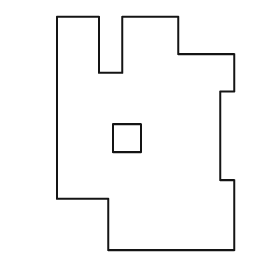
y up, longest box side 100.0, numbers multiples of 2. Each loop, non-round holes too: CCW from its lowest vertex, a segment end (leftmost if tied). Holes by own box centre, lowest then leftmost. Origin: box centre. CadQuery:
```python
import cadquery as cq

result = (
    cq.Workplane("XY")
    .moveTo(-16.0, -50.0)
    .lineTo(38.0, -50.0)
    .lineTo(38.0, -20.0)
    .lineTo(32.0, -20.0)
    .lineTo(32.0, 18.0)
    .lineTo(38.0, 18.0)
    .lineTo(38.0, 34.0)
    .lineTo(14.0, 34.0)
    .lineTo(14.0, 50.0)
    .lineTo(-10.0, 50.0)
    .lineTo(-10.0, 26.0)
    .lineTo(-20.0, 26.0)
    .lineTo(-20.0, 50.0)
    .lineTo(-38.0, 50.0)
    .lineTo(-38.0, -28.0)
    .lineTo(-16.0, -28.0)
    .close()
    .moveTo(-14.0, -8.0)
    .lineTo(-2.0, -8.0)
    .lineTo(-2.0, 4.0)
    .lineTo(-14.0, 4.0)
    .close()
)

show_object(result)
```